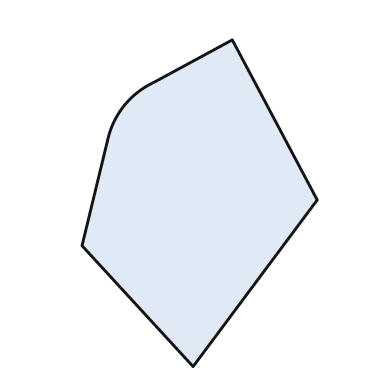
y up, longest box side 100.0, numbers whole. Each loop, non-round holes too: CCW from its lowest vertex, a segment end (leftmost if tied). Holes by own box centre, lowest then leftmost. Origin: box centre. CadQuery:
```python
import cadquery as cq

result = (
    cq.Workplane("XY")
    .moveTo(-2.0, -50.0)
    .lineTo(36.0, 1.0)
    .lineTo(10.0, 50.0)
    .lineTo(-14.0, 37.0)
    .threePointArc((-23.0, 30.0), (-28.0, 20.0))
    .lineTo(-36.0, -13.0)
    .close()
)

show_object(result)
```